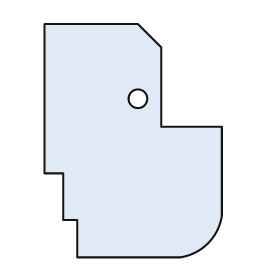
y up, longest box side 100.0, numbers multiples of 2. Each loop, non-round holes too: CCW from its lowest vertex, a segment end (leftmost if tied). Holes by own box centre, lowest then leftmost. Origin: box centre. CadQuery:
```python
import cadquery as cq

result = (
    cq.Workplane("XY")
    .moveTo(-24.0, -50.0)
    .lineTo(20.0, -50.0)
    .threePointArc((32.0, -44.0), (38.0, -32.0))
    .lineTo(38.0, 6.0)
    .lineTo(12.0, 6.0)
    .lineTo(12.0, 40.0)
    .lineTo(2.0, 50.0)
    .lineTo(-38.0, 50.0)
    .lineTo(-38.0, -14.0)
    .lineTo(-30.0, -14.0)
    .lineTo(-30.0, -34.0)
    .lineTo(-24.0, -34.0)
    .close()
    .moveTo(2.0, 18.0)
    .circle(4.0)
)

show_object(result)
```